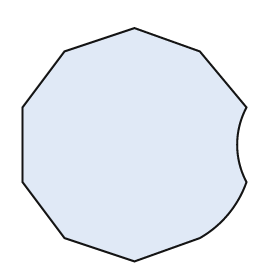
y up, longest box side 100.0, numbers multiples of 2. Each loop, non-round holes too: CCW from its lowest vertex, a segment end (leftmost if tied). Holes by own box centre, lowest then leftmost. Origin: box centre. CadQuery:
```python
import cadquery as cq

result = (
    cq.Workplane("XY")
    .moveTo(0.0, -50.0)
    .lineTo(28.0, -40.0)
    .threePointArc((40.0, -30.0), (48.0, -16.0))
    .threePointArc((44.0, 0.0), (48.0, 16.0))
    .lineTo(28.0, 40.0)
    .lineTo(0.0, 50.0)
    .lineTo(-30.0, 40.0)
    .lineTo(-48.0, 16.0)
    .lineTo(-48.0, -16.0)
    .lineTo(-30.0, -40.0)
    .close()
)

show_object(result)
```